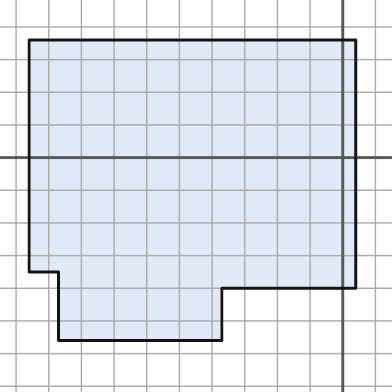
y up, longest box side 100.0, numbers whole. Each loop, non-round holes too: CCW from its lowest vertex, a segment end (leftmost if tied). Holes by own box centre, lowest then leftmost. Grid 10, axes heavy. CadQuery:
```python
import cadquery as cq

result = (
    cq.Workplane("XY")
    .moveTo(-87.0, -56.0)
    .lineTo(-37.0, -56.0)
    .lineTo(-37.0, -40.0)
    .lineTo(4.0, -40.0)
    .lineTo(4.0, 36.0)
    .lineTo(-96.0, 36.0)
    .lineTo(-96.0, -35.0)
    .lineTo(-87.0, -35.0)
    .close()
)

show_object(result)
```